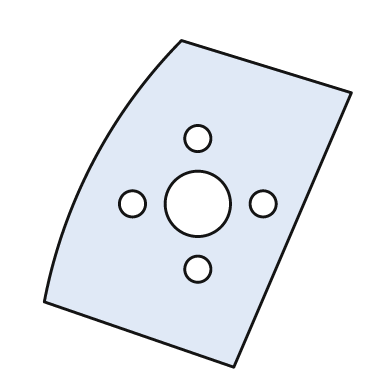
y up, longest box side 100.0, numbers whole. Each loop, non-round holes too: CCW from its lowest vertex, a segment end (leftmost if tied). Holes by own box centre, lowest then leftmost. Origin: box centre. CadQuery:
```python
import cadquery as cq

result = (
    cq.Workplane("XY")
    .moveTo(11.0, -50.0)
    .lineTo(47.0, 34.0)
    .lineTo(-5.0, 50.0)
    .threePointArc((-32.0, 13.0), (-47.0, -30.0))
    .close()
    .moveTo(0.0, -20.0)
    .circle(4.0)
    .moveTo(-20.0, 0.0)
    .circle(4.0)
    .moveTo(0.0, 0.0)
    .circle(10.0)
    .moveTo(20.0, 0.0)
    .circle(4.0)
    .moveTo(0.0, 20.0)
    .circle(4.0)
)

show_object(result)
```